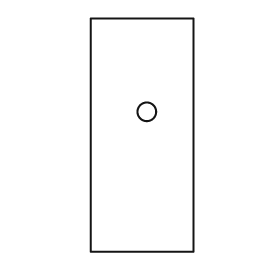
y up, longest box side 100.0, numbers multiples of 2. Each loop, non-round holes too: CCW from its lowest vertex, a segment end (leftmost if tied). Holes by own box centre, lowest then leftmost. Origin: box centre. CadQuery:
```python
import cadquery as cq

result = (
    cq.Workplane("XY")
    .moveTo(-22.0, -50.0)
    .lineTo(22.0, -50.0)
    .lineTo(22.0, 50.0)
    .lineTo(-22.0, 50.0)
    .close()
    .moveTo(2.0, 10.0)
    .circle(4.0)
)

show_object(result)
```